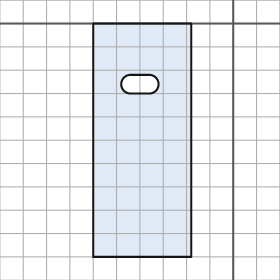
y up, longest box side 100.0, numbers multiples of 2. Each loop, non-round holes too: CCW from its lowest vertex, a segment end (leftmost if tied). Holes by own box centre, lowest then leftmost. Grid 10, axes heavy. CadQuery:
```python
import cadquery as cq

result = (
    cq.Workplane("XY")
    .moveTo(-60.0, -100.0)
    .lineTo(-18.0, -100.0)
    .lineTo(-18.0, 0.0)
    .lineTo(-60.0, 0.0)
    .close()
    .moveTo(-44.0, -30.0)
    .lineTo(-36.0, -30.0)
    .threePointArc((-32.0, -26.0), (-36.0, -22.0))
    .lineTo(-44.0, -22.0)
    .threePointArc((-48.0, -26.0), (-44.0, -30.0))
    .close()
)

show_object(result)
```